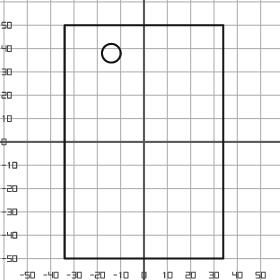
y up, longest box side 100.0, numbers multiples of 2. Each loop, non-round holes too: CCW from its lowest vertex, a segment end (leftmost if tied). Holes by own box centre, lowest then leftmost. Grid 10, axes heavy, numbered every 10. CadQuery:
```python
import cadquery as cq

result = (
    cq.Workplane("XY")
    .moveTo(-34.0, -50.0)
    .lineTo(34.0, -50.0)
    .lineTo(34.0, 50.0)
    .lineTo(-34.0, 50.0)
    .close()
    .moveTo(-14.0, 38.0)
    .circle(4.0)
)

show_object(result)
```